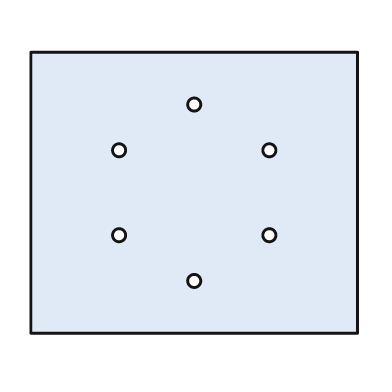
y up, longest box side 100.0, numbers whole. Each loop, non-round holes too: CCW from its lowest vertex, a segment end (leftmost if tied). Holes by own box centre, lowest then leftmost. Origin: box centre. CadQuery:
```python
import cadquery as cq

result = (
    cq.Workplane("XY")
    .moveTo(-50.0, -43.0)
    .lineTo(50.0, -43.0)
    .lineTo(50.0, 43.0)
    .lineTo(-50.0, 43.0)
    .close()
    .moveTo(0.0, -27.0)
    .circle(2.0)
    .moveTo(-23.0, -13.0)
    .circle(2.0)
    .moveTo(23.0, -13.0)
    .circle(2.0)
    .moveTo(-23.0, 13.0)
    .circle(2.0)
    .moveTo(23.0, 13.0)
    .circle(2.0)
    .moveTo(0.0, 27.0)
    .circle(2.0)
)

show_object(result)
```